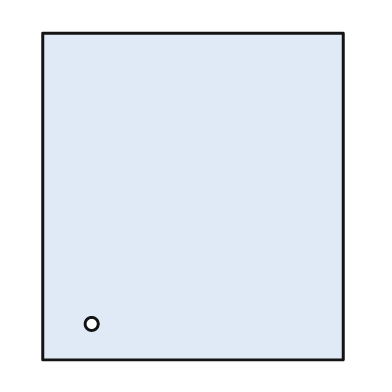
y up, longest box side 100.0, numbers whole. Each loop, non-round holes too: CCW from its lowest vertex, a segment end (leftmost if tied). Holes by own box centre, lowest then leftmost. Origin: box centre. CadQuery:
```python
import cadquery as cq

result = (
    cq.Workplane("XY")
    .moveTo(-46.0, -50.0)
    .lineTo(46.0, -50.0)
    .lineTo(46.0, 50.0)
    .lineTo(-46.0, 50.0)
    .close()
    .moveTo(-31.0, -39.0)
    .circle(2.0)
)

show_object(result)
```